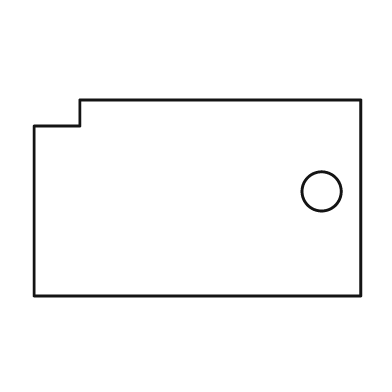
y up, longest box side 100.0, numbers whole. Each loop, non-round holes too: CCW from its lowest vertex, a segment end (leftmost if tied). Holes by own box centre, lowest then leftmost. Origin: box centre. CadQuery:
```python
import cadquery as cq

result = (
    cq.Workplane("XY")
    .moveTo(-50.0, -30.0)
    .lineTo(50.0, -30.0)
    .lineTo(50.0, 30.0)
    .lineTo(-36.0, 30.0)
    .lineTo(-36.0, 22.0)
    .lineTo(-50.0, 22.0)
    .close()
    .moveTo(38.0, 2.0)
    .circle(6.0)
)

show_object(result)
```